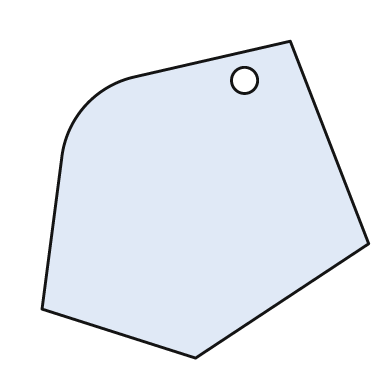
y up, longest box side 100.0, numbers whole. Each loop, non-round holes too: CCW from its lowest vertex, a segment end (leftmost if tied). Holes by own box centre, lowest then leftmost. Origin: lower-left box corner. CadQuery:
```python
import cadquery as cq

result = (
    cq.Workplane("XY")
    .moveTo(47.0, 0.0)
    .lineTo(100.0, 35.0)
    .lineTo(76.0, 97.0)
    .lineTo(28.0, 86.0)
    .threePointArc((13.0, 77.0), (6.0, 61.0))
    .lineTo(0.0, 15.0)
    .close()
    .moveTo(62.0, 85.0)
    .circle(4.0)
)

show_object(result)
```